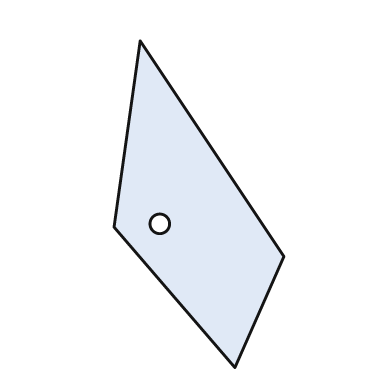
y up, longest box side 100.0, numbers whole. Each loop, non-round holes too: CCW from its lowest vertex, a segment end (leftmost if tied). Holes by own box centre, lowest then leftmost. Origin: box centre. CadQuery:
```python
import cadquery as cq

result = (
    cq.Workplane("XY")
    .moveTo(11.0, -50.0)
    .lineTo(26.0, -16.0)
    .lineTo(-18.0, 50.0)
    .lineTo(-26.0, -7.0)
    .close()
    .moveTo(-12.0, -6.0)
    .circle(3.0)
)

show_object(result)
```